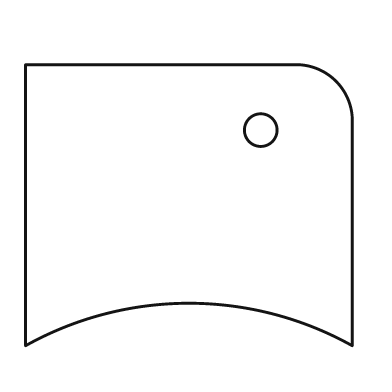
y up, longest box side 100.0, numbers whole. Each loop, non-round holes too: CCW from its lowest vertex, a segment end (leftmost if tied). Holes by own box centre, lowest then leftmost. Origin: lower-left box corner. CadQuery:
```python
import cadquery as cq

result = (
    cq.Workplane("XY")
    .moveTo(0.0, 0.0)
    .threePointArc((50.0, 13.0), (100.0, 0.0))
    .lineTo(100.0, 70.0)
    .threePointArc((95.0, 81.0), (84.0, 86.0))
    .lineTo(0.0, 86.0)
    .close()
    .moveTo(72.0, 66.0)
    .circle(5.0)
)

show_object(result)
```